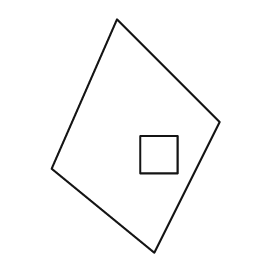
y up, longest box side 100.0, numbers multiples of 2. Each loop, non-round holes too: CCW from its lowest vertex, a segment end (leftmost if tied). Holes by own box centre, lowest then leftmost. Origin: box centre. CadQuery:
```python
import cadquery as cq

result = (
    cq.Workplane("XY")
    .moveTo(8.0, -50.0)
    .lineTo(36.0, 6.0)
    .lineTo(-8.0, 50.0)
    .lineTo(-36.0, -14.0)
    .close()
    .moveTo(2.0, -16.0)
    .lineTo(18.0, -16.0)
    .lineTo(18.0, 0.0)
    .lineTo(2.0, 0.0)
    .close()
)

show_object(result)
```